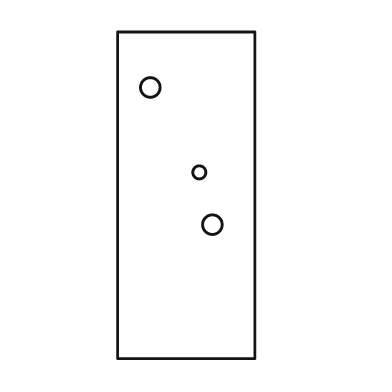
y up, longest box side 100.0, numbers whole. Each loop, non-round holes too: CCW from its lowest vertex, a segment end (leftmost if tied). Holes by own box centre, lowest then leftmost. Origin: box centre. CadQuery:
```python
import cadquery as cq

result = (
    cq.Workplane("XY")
    .moveTo(-21.0, -50.0)
    .lineTo(21.0, -50.0)
    .lineTo(21.0, 50.0)
    .lineTo(-21.0, 50.0)
    .close()
    .moveTo(8.0, -9.0)
    .circle(3.0)
    .moveTo(4.0, 7.0)
    .circle(2.0)
    .moveTo(-11.0, 33.0)
    .circle(3.0)
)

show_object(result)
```